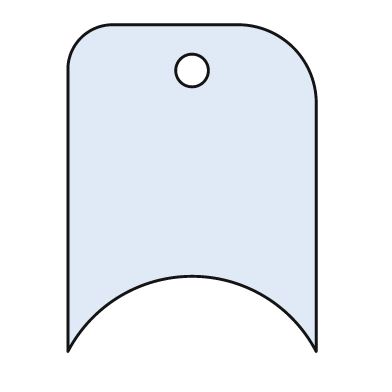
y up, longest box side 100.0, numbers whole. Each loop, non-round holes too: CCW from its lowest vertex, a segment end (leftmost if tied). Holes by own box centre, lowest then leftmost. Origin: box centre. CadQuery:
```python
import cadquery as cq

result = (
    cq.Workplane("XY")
    .moveTo(-38.0, -50.0)
    .threePointArc((0.0, -27.0), (38.0, -50.0))
    .lineTo(38.0, 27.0)
    .threePointArc((31.0, 43.0), (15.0, 50.0))
    .lineTo(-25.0, 50.0)
    .threePointArc((-34.0, 46.0), (-38.0, 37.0))
    .close()
    .moveTo(0.0, 36.0)
    .circle(5.0)
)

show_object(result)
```